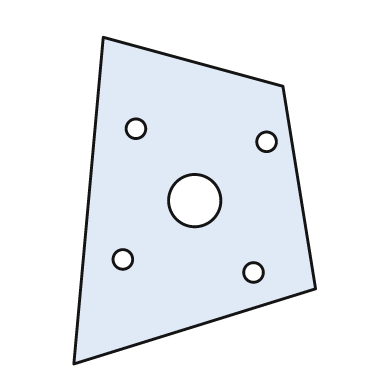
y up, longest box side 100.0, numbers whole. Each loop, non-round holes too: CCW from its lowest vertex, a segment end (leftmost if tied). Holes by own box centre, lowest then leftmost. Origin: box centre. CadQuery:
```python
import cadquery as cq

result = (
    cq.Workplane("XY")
    .moveTo(-37.0, -50.0)
    .lineTo(37.0, -27.0)
    .lineTo(27.0, 35.0)
    .lineTo(-28.0, 50.0)
    .close()
    .moveTo(18.0, -22.0)
    .circle(3.0)
    .moveTo(-22.0, -18.0)
    .circle(3.0)
    .moveTo(0.0, 0.0)
    .circle(8.0)
    .moveTo(22.0, 18.0)
    .circle(3.0)
    .moveTo(-18.0, 22.0)
    .circle(3.0)
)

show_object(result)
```